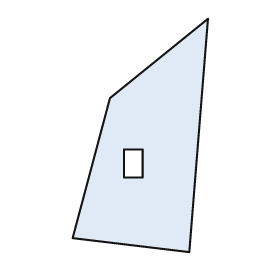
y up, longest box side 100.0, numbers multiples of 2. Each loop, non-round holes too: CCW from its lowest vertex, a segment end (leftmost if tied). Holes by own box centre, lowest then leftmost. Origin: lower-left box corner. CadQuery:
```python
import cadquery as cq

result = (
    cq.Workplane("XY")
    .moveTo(50.0, 0.0)
    .lineTo(58.0, 100.0)
    .lineTo(16.0, 66.0)
    .lineTo(0.0, 6.0)
    .close()
    .moveTo(22.0, 32.0)
    .lineTo(30.0, 32.0)
    .lineTo(30.0, 44.0)
    .lineTo(22.0, 44.0)
    .close()
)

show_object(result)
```